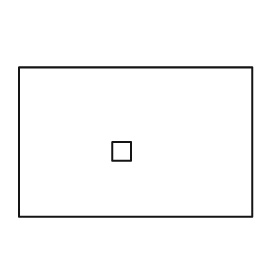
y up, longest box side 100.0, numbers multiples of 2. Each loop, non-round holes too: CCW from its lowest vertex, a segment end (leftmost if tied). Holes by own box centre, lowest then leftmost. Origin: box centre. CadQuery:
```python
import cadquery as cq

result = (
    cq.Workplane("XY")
    .moveTo(-50.0, -32.0)
    .lineTo(50.0, -32.0)
    .lineTo(50.0, 32.0)
    .lineTo(-50.0, 32.0)
    .close()
    .moveTo(-10.0, -8.0)
    .lineTo(-2.0, -8.0)
    .lineTo(-2.0, 0.0)
    .lineTo(-10.0, 0.0)
    .close()
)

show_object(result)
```